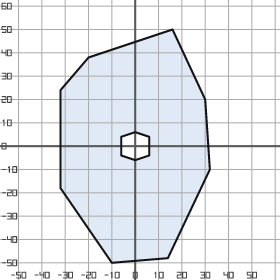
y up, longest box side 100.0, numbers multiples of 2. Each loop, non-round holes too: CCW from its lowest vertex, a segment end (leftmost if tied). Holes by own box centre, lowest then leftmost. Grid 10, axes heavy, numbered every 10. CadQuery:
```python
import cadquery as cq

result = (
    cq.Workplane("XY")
    .moveTo(-10.0, -50.0)
    .lineTo(14.0, -48.0)
    .lineTo(32.0, -10.0)
    .lineTo(30.0, 20.0)
    .lineTo(16.0, 50.0)
    .lineTo(-20.0, 38.0)
    .lineTo(-32.0, 24.0)
    .lineTo(-32.0, -18.0)
    .close()
    .moveTo(0.0, -6.0)
    .lineTo(6.0, -4.0)
    .lineTo(6.0, 4.0)
    .lineTo(0.0, 6.0)
    .lineTo(-6.0, 4.0)
    .lineTo(-6.0, -4.0)
    .close()
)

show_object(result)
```